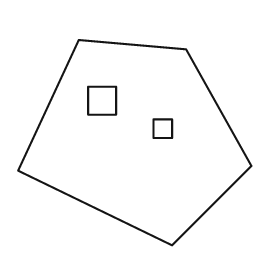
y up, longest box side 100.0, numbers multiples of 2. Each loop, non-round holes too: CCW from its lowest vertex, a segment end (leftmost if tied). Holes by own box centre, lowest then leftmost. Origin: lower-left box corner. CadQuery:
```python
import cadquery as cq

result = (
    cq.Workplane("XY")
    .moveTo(66.0, 0.0)
    .lineTo(100.0, 34.0)
    .lineTo(72.0, 84.0)
    .lineTo(26.0, 88.0)
    .lineTo(0.0, 32.0)
    .close()
    .moveTo(58.0, 46.0)
    .lineTo(66.0, 46.0)
    .lineTo(66.0, 54.0)
    .lineTo(58.0, 54.0)
    .close()
    .moveTo(30.0, 56.0)
    .lineTo(42.0, 56.0)
    .lineTo(42.0, 68.0)
    .lineTo(30.0, 68.0)
    .close()
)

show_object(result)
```